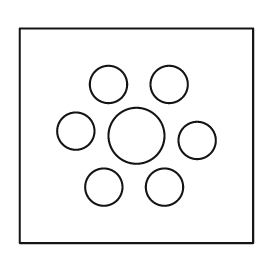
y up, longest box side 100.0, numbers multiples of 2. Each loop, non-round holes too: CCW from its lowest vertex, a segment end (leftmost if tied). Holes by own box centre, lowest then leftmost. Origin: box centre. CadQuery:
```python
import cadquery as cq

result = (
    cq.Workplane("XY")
    .moveTo(-50.0, -46.0)
    .lineTo(50.0, -46.0)
    .lineTo(50.0, 46.0)
    .lineTo(-50.0, 46.0)
    .close()
    .moveTo(-14.0, -22.0)
    .circle(8.0)
    .moveTo(12.0, -22.0)
    .circle(8.0)
    .moveTo(26.0, -2.0)
    .circle(8.0)
    .moveTo(0.0, 0.0)
    .circle(12.0)
    .moveTo(-26.0, 2.0)
    .circle(8.0)
    .moveTo(-12.0, 22.0)
    .circle(8.0)
    .moveTo(14.0, 22.0)
    .circle(8.0)
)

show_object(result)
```